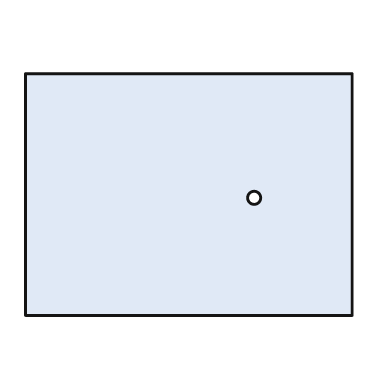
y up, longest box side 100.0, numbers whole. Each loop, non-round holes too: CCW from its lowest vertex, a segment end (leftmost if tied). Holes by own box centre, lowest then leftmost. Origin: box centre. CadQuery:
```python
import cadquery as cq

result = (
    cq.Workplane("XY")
    .moveTo(-50.0, -37.0)
    .lineTo(50.0, -37.0)
    .lineTo(50.0, 37.0)
    .lineTo(-50.0, 37.0)
    .close()
    .moveTo(20.0, -1.0)
    .circle(2.0)
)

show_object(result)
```